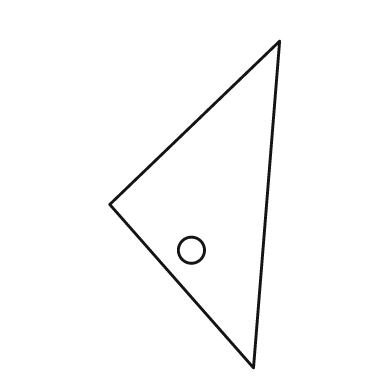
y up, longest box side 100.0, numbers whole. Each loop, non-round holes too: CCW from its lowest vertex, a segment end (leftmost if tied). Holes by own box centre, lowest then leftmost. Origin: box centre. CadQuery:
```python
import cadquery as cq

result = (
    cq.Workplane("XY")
    .moveTo(18.0, -50.0)
    .lineTo(26.0, 50.0)
    .lineTo(-26.0, 0.0)
    .close()
    .moveTo(-1.0, -14.0)
    .circle(4.0)
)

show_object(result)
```